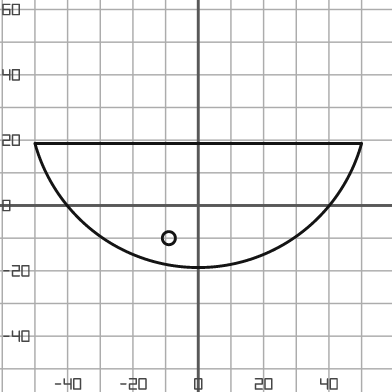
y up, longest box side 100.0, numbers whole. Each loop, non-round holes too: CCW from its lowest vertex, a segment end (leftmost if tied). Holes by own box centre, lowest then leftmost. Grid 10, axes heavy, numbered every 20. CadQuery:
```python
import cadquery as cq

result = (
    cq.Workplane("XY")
    .moveTo(-50.0, 19.0)
    .threePointArc((0.0, -19.0), (50.0, 19.0))
    .close()
    .moveTo(-9.0, -10.0)
    .circle(2.0)
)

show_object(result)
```